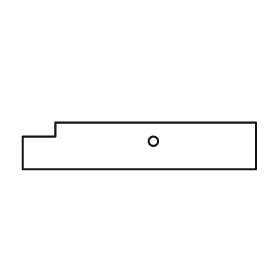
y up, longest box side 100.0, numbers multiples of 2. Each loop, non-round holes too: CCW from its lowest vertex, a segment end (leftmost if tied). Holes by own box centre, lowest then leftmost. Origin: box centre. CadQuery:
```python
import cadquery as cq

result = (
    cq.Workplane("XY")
    .moveTo(-50.0, -10.0)
    .lineTo(50.0, -10.0)
    .lineTo(50.0, 10.0)
    .lineTo(-36.0, 10.0)
    .lineTo(-36.0, 4.0)
    .lineTo(-50.0, 4.0)
    .close()
    .moveTo(6.0, 2.0)
    .circle(2.0)
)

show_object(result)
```